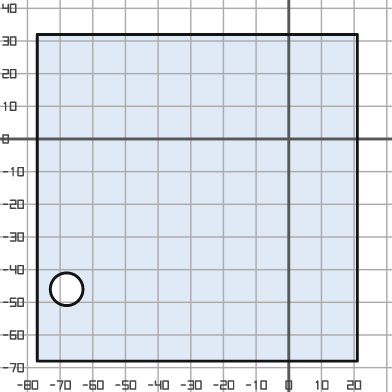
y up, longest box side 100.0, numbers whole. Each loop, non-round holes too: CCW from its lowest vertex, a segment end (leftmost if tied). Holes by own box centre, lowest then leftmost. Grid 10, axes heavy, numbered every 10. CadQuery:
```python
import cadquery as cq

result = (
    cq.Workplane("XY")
    .moveTo(-77.0, -68.0)
    .lineTo(21.0, -68.0)
    .lineTo(21.0, 32.0)
    .lineTo(-77.0, 32.0)
    .close()
    .moveTo(-68.0, -46.0)
    .circle(5.0)
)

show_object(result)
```